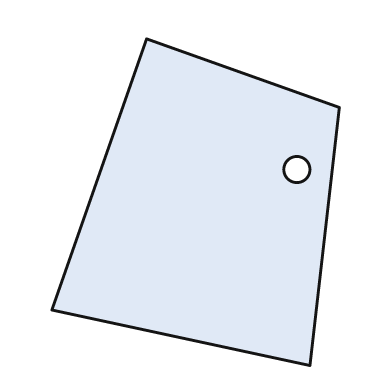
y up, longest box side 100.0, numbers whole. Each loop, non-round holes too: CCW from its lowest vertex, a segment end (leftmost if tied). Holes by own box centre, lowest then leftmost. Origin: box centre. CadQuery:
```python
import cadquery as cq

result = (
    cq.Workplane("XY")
    .moveTo(35.0, -50.0)
    .lineTo(44.0, 29.0)
    .lineTo(-15.0, 50.0)
    .lineTo(-44.0, -33.0)
    .close()
    .moveTo(31.0, 10.0)
    .circle(4.0)
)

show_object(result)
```